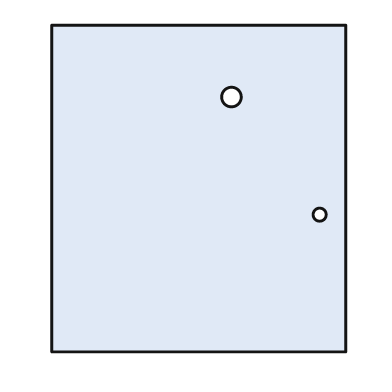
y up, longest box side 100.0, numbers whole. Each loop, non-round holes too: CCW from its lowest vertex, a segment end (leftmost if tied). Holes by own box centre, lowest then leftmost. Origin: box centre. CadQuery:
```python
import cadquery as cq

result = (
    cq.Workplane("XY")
    .moveTo(-45.0, -50.0)
    .lineTo(45.0, -50.0)
    .lineTo(45.0, 50.0)
    .lineTo(-45.0, 50.0)
    .close()
    .moveTo(37.0, -8.0)
    .circle(2.0)
    .moveTo(10.0, 28.0)
    .circle(3.0)
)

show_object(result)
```